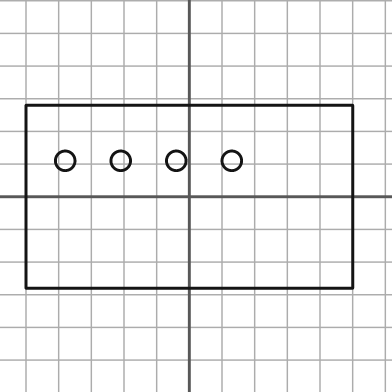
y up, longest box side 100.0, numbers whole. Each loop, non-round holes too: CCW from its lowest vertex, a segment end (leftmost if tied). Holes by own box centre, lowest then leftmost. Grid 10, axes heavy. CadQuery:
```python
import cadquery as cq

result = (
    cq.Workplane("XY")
    .moveTo(-50.0, -28.0)
    .lineTo(50.0, -28.0)
    .lineTo(50.0, 28.0)
    .lineTo(-50.0, 28.0)
    .close()
    .moveTo(-38.0, 11.0)
    .circle(3.0)
    .moveTo(-21.0, 11.0)
    .circle(3.0)
    .moveTo(-4.0, 11.0)
    .circle(3.0)
    .moveTo(13.0, 11.0)
    .circle(3.0)
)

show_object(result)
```